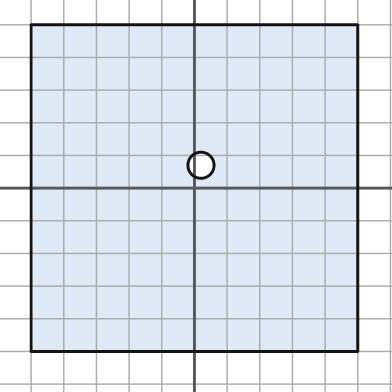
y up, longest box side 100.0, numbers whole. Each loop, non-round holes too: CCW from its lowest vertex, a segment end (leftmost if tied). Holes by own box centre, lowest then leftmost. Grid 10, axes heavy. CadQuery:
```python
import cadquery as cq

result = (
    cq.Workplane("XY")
    .moveTo(-50.0, -50.0)
    .lineTo(50.0, -50.0)
    .lineTo(50.0, 50.0)
    .lineTo(-50.0, 50.0)
    .close()
    .moveTo(2.0, 7.0)
    .circle(4.0)
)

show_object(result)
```